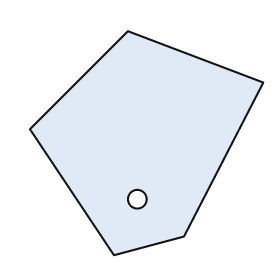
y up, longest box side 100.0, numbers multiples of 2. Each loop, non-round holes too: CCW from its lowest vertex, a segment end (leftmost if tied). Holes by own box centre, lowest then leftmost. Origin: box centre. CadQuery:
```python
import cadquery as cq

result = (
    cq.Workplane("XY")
    .moveTo(-14.0, -48.0)
    .lineTo(16.0, -40.0)
    .lineTo(50.0, 26.0)
    .lineTo(-8.0, 48.0)
    .lineTo(-50.0, 6.0)
    .close()
    .moveTo(-4.0, -24.0)
    .circle(4.0)
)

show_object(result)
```